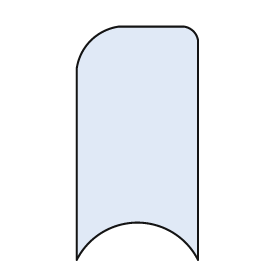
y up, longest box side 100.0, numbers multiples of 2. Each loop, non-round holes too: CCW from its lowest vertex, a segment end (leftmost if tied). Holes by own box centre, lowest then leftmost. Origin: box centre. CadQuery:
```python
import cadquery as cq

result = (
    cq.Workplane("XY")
    .moveTo(-26.0, -50.0)
    .threePointArc((0.0, -34.0), (26.0, -50.0))
    .lineTo(26.0, 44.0)
    .threePointArc((24.0, 48.0), (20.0, 50.0))
    .lineTo(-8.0, 50.0)
    .threePointArc((-20.0, 44.0), (-26.0, 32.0))
    .close()
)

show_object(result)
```